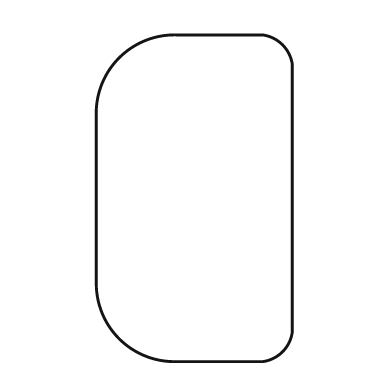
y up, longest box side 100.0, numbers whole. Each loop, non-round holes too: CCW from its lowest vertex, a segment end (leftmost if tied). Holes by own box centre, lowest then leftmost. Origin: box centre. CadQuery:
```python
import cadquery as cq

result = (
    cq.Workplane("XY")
    .moveTo(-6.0, -50.0)
    .lineTo(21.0, -50.0)
    .threePointArc((27.0, -47.0), (30.0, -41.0))
    .lineTo(30.0, 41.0)
    .threePointArc((27.0, 47.0), (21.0, 50.0))
    .lineTo(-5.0, 50.0)
    .threePointArc((-23.0, 43.0), (-30.0, 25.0))
    .lineTo(-30.0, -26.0)
    .threePointArc((-23.0, -43.0), (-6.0, -50.0))
    .close()
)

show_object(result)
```